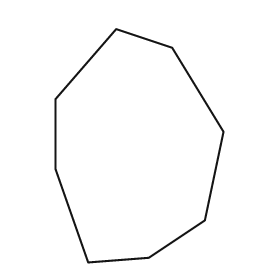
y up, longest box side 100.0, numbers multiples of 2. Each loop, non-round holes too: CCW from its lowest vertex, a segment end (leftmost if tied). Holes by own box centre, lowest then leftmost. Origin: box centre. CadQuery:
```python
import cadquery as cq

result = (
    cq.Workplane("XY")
    .moveTo(-22.0, -50.0)
    .lineTo(4.0, -48.0)
    .lineTo(28.0, -32.0)
    .lineTo(36.0, 6.0)
    .lineTo(14.0, 42.0)
    .lineTo(-10.0, 50.0)
    .lineTo(-36.0, 20.0)
    .lineTo(-36.0, -10.0)
    .close()
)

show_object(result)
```